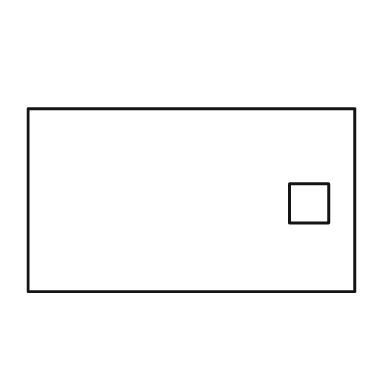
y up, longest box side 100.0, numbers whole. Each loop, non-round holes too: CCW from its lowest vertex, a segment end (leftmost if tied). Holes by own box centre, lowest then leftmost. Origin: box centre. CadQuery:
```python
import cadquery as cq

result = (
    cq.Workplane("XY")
    .moveTo(-50.0, -28.0)
    .lineTo(50.0, -28.0)
    .lineTo(50.0, 28.0)
    .lineTo(-50.0, 28.0)
    .close()
    .moveTo(30.0, -7.0)
    .lineTo(42.0, -7.0)
    .lineTo(42.0, 5.0)
    .lineTo(30.0, 5.0)
    .close()
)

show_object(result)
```